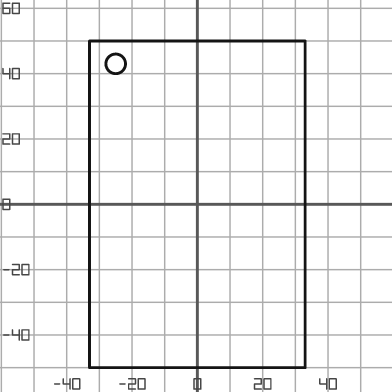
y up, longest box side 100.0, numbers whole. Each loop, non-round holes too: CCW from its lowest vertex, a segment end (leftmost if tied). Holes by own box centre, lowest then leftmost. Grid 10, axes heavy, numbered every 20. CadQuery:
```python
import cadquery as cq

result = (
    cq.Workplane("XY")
    .moveTo(-33.0, -50.0)
    .lineTo(33.0, -50.0)
    .lineTo(33.0, 50.0)
    .lineTo(-33.0, 50.0)
    .close()
    .moveTo(-25.0, 43.0)
    .circle(3.0)
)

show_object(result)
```